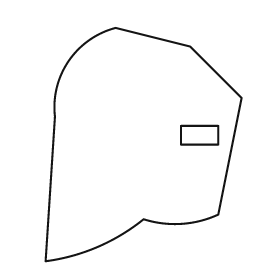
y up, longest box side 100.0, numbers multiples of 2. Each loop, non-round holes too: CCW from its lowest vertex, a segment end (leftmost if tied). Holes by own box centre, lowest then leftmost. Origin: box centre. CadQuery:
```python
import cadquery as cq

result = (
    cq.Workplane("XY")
    .moveTo(-42.0, -50.0)
    .threePointArc((-20.0, -44.0), (0.0, -32.0))
    .threePointArc((16.0, -34.0), (32.0, -30.0))
    .lineTo(42.0, 20.0)
    .lineTo(20.0, 42.0)
    .lineTo(-12.0, 50.0)
    .threePointArc((-32.0, 36.0), (-38.0, 12.0))
    .close()
    .moveTo(16.0, 0.0)
    .lineTo(32.0, 0.0)
    .lineTo(32.0, 8.0)
    .lineTo(16.0, 8.0)
    .close()
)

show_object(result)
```